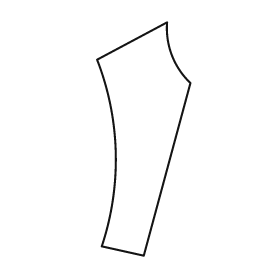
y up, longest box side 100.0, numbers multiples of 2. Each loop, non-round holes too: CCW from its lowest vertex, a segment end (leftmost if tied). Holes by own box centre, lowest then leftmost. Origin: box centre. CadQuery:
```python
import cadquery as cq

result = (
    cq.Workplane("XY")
    .moveTo(0.0, -50.0)
    .lineTo(20.0, 24.0)
    .threePointArc((12.0, 36.0), (10.0, 50.0))
    .lineTo(-20.0, 34.0)
    .threePointArc((-12.0, -6.0), (-18.0, -46.0))
    .close()
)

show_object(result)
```